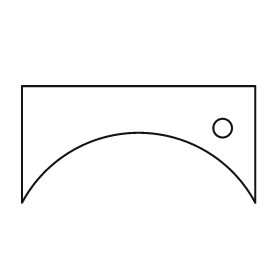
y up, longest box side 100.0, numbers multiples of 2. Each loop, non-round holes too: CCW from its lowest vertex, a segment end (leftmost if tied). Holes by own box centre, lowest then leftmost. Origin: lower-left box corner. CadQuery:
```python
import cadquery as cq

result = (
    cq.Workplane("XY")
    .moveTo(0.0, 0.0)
    .threePointArc((50.0, 30.0), (100.0, 0.0))
    .lineTo(100.0, 50.0)
    .lineTo(0.0, 50.0)
    .close()
    .moveTo(86.0, 32.0)
    .circle(4.0)
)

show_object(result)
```